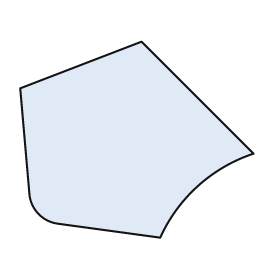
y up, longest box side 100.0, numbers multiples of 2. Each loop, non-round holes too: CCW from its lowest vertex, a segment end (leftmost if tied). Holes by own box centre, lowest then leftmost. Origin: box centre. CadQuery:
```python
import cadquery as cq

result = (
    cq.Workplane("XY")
    .moveTo(10.0, -42.0)
    .threePointArc((26.0, -20.0), (50.0, -6.0))
    .lineTo(2.0, 42.0)
    .lineTo(-50.0, 22.0)
    .lineTo(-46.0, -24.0)
    .threePointArc((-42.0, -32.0), (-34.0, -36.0))
    .close()
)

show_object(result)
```